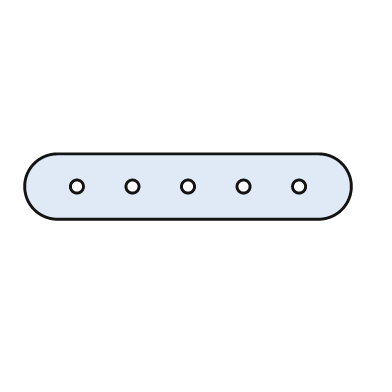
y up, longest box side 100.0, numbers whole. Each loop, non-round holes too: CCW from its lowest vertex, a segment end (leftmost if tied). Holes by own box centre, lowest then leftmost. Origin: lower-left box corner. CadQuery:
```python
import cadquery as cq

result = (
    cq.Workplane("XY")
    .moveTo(10.0, 0.0)
    .lineTo(90.0, 0.0)
    .threePointArc((100.0, 10.0), (90.0, 20.0))
    .lineTo(10.0, 20.0)
    .threePointArc((0.0, 10.0), (10.0, 0.0))
    .close()
    .moveTo(16.0, 10.0)
    .circle(2.0)
    .moveTo(33.0, 10.0)
    .circle(2.0)
    .moveTo(50.0, 10.0)
    .circle(2.0)
    .moveTo(67.0, 10.0)
    .circle(2.0)
    .moveTo(84.0, 10.0)
    .circle(2.0)
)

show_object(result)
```